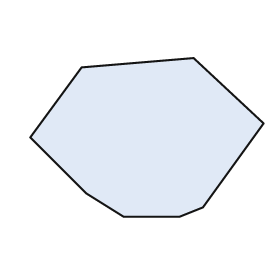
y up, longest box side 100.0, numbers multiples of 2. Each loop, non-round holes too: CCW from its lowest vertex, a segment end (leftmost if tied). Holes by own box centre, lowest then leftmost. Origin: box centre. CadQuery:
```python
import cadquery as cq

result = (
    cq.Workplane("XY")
    .moveTo(-10.0, -34.0)
    .lineTo(14.0, -34.0)
    .lineTo(24.0, -30.0)
    .lineTo(50.0, 6.0)
    .lineTo(20.0, 34.0)
    .lineTo(-28.0, 30.0)
    .lineTo(-50.0, 0.0)
    .lineTo(-26.0, -24.0)
    .close()
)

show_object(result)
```